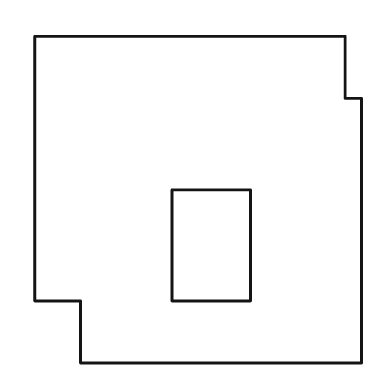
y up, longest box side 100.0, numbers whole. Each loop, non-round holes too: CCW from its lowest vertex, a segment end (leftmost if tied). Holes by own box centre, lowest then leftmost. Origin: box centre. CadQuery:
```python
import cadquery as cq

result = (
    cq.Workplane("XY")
    .moveTo(-36.0, -50.0)
    .lineTo(50.0, -50.0)
    .lineTo(50.0, 31.0)
    .lineTo(45.0, 31.0)
    .lineTo(45.0, 50.0)
    .lineTo(-50.0, 50.0)
    .lineTo(-50.0, -31.0)
    .lineTo(-36.0, -31.0)
    .close()
    .moveTo(-8.0, -31.0)
    .lineTo(16.0, -31.0)
    .lineTo(16.0, 3.0)
    .lineTo(-8.0, 3.0)
    .close()
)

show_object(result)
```